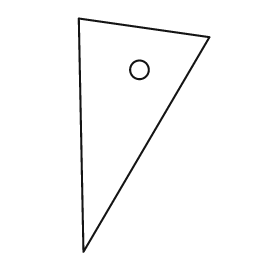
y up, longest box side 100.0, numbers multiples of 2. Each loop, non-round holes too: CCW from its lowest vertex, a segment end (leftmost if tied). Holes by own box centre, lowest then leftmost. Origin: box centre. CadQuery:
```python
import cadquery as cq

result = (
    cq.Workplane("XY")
    .moveTo(-26.0, -50.0)
    .lineTo(28.0, 42.0)
    .lineTo(-28.0, 50.0)
    .close()
    .moveTo(-2.0, 28.0)
    .circle(4.0)
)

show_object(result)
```